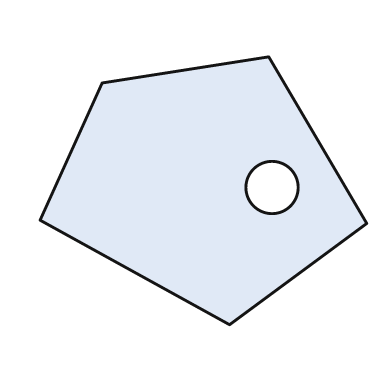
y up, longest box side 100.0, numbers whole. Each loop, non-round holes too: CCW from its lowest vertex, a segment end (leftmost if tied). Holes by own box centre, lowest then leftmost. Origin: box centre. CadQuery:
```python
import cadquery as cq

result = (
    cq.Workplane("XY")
    .moveTo(8.0, -41.0)
    .lineTo(50.0, -10.0)
    .lineTo(20.0, 41.0)
    .lineTo(-31.0, 33.0)
    .lineTo(-50.0, -9.0)
    .close()
    .moveTo(21.0, 1.0)
    .circle(8.0)
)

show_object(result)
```